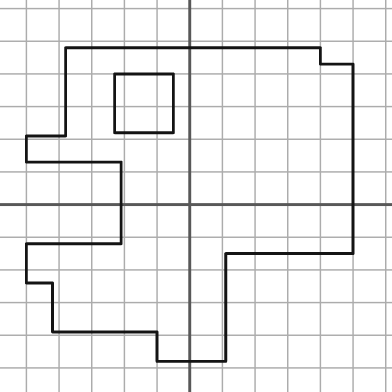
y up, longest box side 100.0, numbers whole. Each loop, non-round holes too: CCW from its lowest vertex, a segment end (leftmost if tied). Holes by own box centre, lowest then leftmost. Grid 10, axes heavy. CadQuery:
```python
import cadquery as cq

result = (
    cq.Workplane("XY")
    .moveTo(-10.0, -48.0)
    .lineTo(11.0, -48.0)
    .lineTo(11.0, -15.0)
    .lineTo(50.0, -15.0)
    .lineTo(50.0, 43.0)
    .lineTo(40.0, 43.0)
    .lineTo(40.0, 48.0)
    .lineTo(-38.0, 48.0)
    .lineTo(-38.0, 21.0)
    .lineTo(-50.0, 21.0)
    .lineTo(-50.0, 13.0)
    .lineTo(-21.0, 13.0)
    .lineTo(-21.0, -12.0)
    .lineTo(-50.0, -12.0)
    .lineTo(-50.0, -24.0)
    .lineTo(-42.0, -24.0)
    .lineTo(-42.0, -39.0)
    .lineTo(-10.0, -39.0)
    .close()
    .moveTo(-23.0, 22.0)
    .lineTo(-5.0, 22.0)
    .lineTo(-5.0, 40.0)
    .lineTo(-23.0, 40.0)
    .close()
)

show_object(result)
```